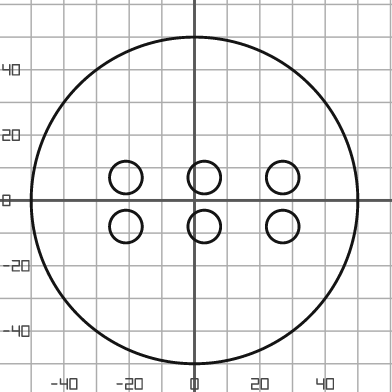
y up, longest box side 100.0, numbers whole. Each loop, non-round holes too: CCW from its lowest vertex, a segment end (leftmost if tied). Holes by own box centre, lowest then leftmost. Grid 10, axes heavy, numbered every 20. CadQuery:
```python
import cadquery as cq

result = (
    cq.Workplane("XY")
    .moveTo(0.0, 0.0)
    .circle(50.0)
    .moveTo(-21.0, -8.0)
    .circle(5.0)
    .moveTo(3.0, -8.0)
    .circle(5.0)
    .moveTo(27.0, -8.0)
    .circle(5.0)
    .moveTo(-21.0, 7.0)
    .circle(5.0)
    .moveTo(3.0, 7.0)
    .circle(5.0)
    .moveTo(27.0, 7.0)
    .circle(5.0)
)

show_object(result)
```